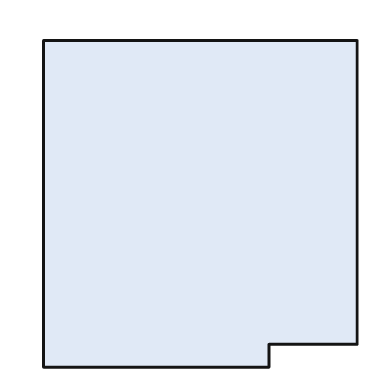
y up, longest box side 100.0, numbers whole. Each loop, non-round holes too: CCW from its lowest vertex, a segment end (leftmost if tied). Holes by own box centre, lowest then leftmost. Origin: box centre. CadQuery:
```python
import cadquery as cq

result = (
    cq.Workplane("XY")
    .moveTo(-48.0, -50.0)
    .lineTo(21.0, -50.0)
    .lineTo(21.0, -43.0)
    .lineTo(48.0, -43.0)
    .lineTo(48.0, 50.0)
    .lineTo(-48.0, 50.0)
    .close()
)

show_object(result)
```